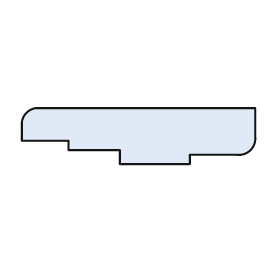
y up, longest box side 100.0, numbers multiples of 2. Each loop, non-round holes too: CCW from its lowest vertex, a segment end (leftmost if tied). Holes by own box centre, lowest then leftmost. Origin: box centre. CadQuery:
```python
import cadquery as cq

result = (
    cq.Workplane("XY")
    .moveTo(-8.0, -12.0)
    .lineTo(22.0, -12.0)
    .lineTo(22.0, -8.0)
    .lineTo(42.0, -8.0)
    .threePointArc((48.0, -6.0), (50.0, 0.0))
    .lineTo(50.0, 12.0)
    .lineTo(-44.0, 12.0)
    .threePointArc((-48.0, 10.0), (-50.0, 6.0))
    .lineTo(-50.0, -2.0)
    .lineTo(-30.0, -2.0)
    .lineTo(-30.0, -6.0)
    .lineTo(-8.0, -6.0)
    .close()
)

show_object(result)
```